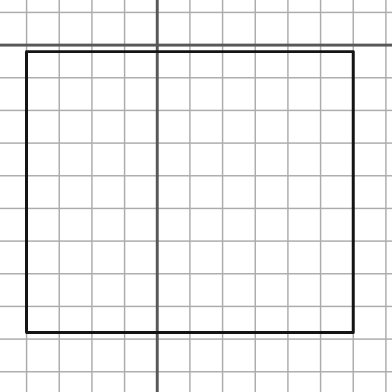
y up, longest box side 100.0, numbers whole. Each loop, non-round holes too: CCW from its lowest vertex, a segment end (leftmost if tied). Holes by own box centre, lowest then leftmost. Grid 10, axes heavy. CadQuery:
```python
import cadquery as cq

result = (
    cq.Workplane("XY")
    .moveTo(-40.0, -88.0)
    .lineTo(60.0, -88.0)
    .lineTo(60.0, -2.0)
    .lineTo(-40.0, -2.0)
    .close()
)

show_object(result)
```